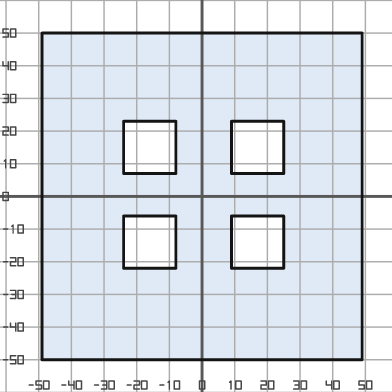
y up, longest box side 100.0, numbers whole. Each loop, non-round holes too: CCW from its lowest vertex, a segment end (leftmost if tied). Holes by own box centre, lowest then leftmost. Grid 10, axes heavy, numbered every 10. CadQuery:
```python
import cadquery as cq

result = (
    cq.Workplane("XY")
    .moveTo(-49.0, -50.0)
    .lineTo(49.0, -50.0)
    .lineTo(49.0, 50.0)
    .lineTo(-49.0, 50.0)
    .close()
    .moveTo(-24.0, -22.0)
    .lineTo(-8.0, -22.0)
    .lineTo(-8.0, -6.0)
    .lineTo(-24.0, -6.0)
    .close()
    .moveTo(9.0, -22.0)
    .lineTo(25.0, -22.0)
    .lineTo(25.0, -6.0)
    .lineTo(9.0, -6.0)
    .close()
    .moveTo(-24.0, 7.0)
    .lineTo(-8.0, 7.0)
    .lineTo(-8.0, 23.0)
    .lineTo(-24.0, 23.0)
    .close()
    .moveTo(9.0, 7.0)
    .lineTo(25.0, 7.0)
    .lineTo(25.0, 23.0)
    .lineTo(9.0, 23.0)
    .close()
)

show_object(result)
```